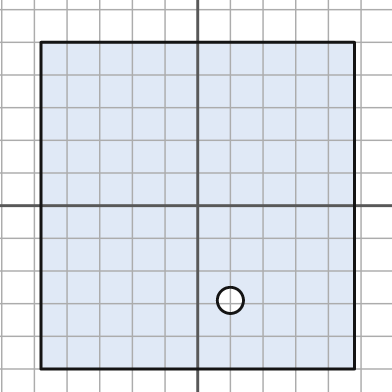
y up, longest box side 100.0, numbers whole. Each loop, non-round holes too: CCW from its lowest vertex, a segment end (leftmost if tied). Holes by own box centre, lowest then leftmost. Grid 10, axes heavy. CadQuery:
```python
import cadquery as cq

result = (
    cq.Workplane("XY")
    .moveTo(-48.0, -50.0)
    .lineTo(48.0, -50.0)
    .lineTo(48.0, 50.0)
    .lineTo(-48.0, 50.0)
    .close()
    .moveTo(10.0, -29.0)
    .circle(4.0)
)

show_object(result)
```